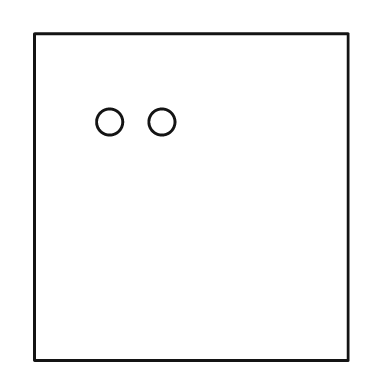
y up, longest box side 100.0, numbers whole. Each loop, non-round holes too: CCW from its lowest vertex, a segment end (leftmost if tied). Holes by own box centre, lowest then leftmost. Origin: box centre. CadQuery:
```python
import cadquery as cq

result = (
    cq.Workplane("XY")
    .moveTo(-48.0, -50.0)
    .lineTo(48.0, -50.0)
    .lineTo(48.0, 50.0)
    .lineTo(-48.0, 50.0)
    .close()
    .moveTo(-25.0, 23.0)
    .circle(4.0)
    .moveTo(-9.0, 23.0)
    .circle(4.0)
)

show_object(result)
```